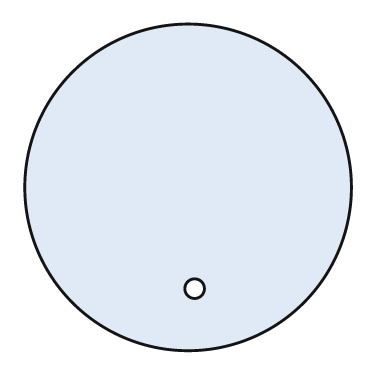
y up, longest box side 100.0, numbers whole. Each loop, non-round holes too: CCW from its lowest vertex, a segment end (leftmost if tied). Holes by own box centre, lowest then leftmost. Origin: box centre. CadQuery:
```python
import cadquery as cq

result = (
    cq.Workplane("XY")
    .moveTo(0.0, 0.0)
    .circle(50.0)
    .moveTo(2.0, -31.0)
    .circle(3.0)
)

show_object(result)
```